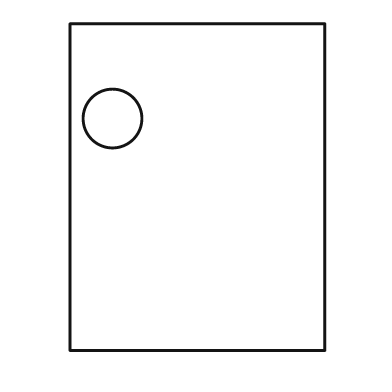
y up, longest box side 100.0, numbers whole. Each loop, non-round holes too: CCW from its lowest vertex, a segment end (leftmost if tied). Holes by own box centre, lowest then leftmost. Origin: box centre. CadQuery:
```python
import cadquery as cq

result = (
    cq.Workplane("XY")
    .moveTo(-39.0, -50.0)
    .lineTo(39.0, -50.0)
    .lineTo(39.0, 50.0)
    .lineTo(-39.0, 50.0)
    .close()
    .moveTo(-26.0, 21.0)
    .circle(9.0)
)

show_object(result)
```